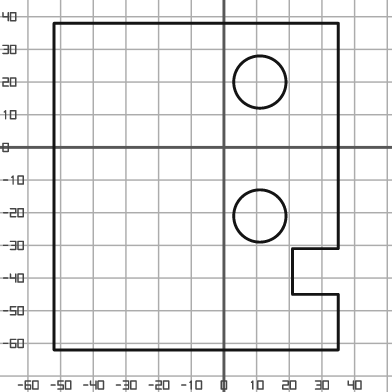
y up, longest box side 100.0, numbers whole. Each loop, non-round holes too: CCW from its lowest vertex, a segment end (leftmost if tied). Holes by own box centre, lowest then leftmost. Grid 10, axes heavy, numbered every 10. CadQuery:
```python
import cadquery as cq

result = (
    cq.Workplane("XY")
    .moveTo(-52.0, -62.0)
    .lineTo(35.0, -62.0)
    .lineTo(35.0, -45.0)
    .lineTo(21.0, -45.0)
    .lineTo(21.0, -31.0)
    .lineTo(35.0, -31.0)
    .lineTo(35.0, 38.0)
    .lineTo(-52.0, 38.0)
    .close()
    .moveTo(11.0, -21.0)
    .circle(8.0)
    .moveTo(11.0, 20.0)
    .circle(8.0)
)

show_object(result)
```